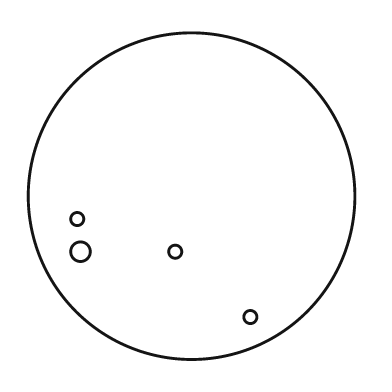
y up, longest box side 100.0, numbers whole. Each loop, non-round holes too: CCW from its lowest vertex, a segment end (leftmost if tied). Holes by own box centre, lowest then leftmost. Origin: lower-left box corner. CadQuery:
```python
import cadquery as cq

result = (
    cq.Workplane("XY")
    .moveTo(50.0, 50.0)
    .circle(50.0)
    .moveTo(68.0, 13.0)
    .circle(2.0)
    .moveTo(16.0, 33.0)
    .circle(3.0)
    .moveTo(45.0, 33.0)
    .circle(2.0)
    .moveTo(15.0, 43.0)
    .circle(2.0)
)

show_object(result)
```